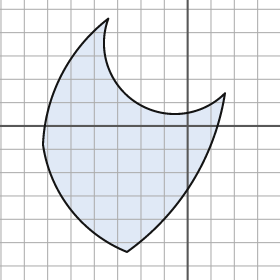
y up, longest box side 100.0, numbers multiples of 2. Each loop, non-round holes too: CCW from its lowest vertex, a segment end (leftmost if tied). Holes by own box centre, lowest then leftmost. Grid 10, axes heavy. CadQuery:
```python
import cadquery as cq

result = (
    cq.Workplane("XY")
    .moveTo(-26.0, -54.0)
    .threePointArc((2.0, -24.0), (16.0, 14.0))
    .threePointArc((-22.0, 10.0), (-34.0, 46.0))
    .threePointArc((-54.0, 22.0), (-62.0, -8.0))
    .threePointArc((-50.0, -36.0), (-26.0, -54.0))
    .close()
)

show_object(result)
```